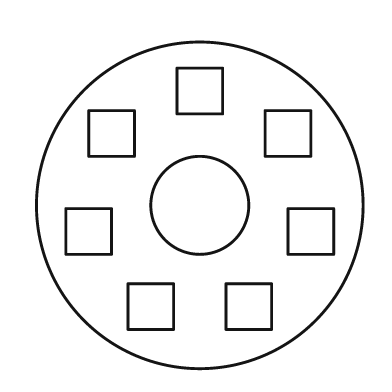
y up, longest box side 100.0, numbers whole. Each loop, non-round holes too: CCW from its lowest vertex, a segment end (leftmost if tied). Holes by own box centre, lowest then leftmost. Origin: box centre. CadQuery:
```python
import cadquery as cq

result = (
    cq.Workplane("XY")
    .moveTo(0.0, 0.0)
    .circle(50.0)
    .moveTo(-22.0, -38.0)
    .lineTo(-8.0, -38.0)
    .lineTo(-8.0, -24.0)
    .lineTo(-22.0, -24.0)
    .close()
    .moveTo(8.0, -38.0)
    .lineTo(22.0, -38.0)
    .lineTo(22.0, -24.0)
    .lineTo(8.0, -24.0)
    .close()
    .moveTo(-41.0, -15.0)
    .lineTo(-27.0, -15.0)
    .lineTo(-27.0, -1.0)
    .lineTo(-41.0, -1.0)
    .close()
    .moveTo(27.0, -15.0)
    .lineTo(41.0, -15.0)
    .lineTo(41.0, -1.0)
    .lineTo(27.0, -1.0)
    .close()
    .moveTo(0.0, 0.0)
    .circle(15.0)
    .moveTo(-34.0, 15.0)
    .lineTo(-20.0, 15.0)
    .lineTo(-20.0, 29.0)
    .lineTo(-34.0, 29.0)
    .close()
    .moveTo(20.0, 15.0)
    .lineTo(34.0, 15.0)
    .lineTo(34.0, 29.0)
    .lineTo(20.0, 29.0)
    .close()
    .moveTo(-7.0, 28.0)
    .lineTo(7.0, 28.0)
    .lineTo(7.0, 42.0)
    .lineTo(-7.0, 42.0)
    .close()
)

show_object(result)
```